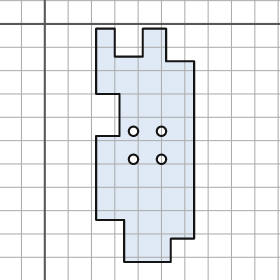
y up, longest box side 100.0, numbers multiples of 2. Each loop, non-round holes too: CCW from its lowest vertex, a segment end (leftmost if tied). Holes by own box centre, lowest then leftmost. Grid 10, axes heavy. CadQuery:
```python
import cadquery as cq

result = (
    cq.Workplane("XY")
    .moveTo(34.0, -102.0)
    .lineTo(54.0, -102.0)
    .lineTo(54.0, -92.0)
    .lineTo(64.0, -92.0)
    .lineTo(64.0, -16.0)
    .lineTo(52.0, -16.0)
    .lineTo(52.0, -2.0)
    .lineTo(42.0, -2.0)
    .lineTo(42.0, -14.0)
    .lineTo(30.0, -14.0)
    .lineTo(30.0, -2.0)
    .lineTo(22.0, -2.0)
    .lineTo(22.0, -30.0)
    .lineTo(32.0, -30.0)
    .lineTo(32.0, -48.0)
    .lineTo(22.0, -48.0)
    .lineTo(22.0, -84.0)
    .lineTo(34.0, -84.0)
    .close()
    .moveTo(38.0, -58.0)
    .circle(2.0)
    .moveTo(50.0, -58.0)
    .circle(2.0)
    .moveTo(38.0, -46.0)
    .circle(2.0)
    .moveTo(50.0, -46.0)
    .circle(2.0)
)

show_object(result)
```